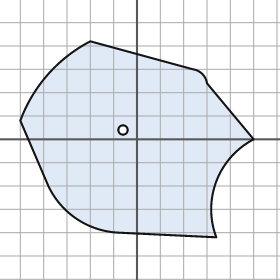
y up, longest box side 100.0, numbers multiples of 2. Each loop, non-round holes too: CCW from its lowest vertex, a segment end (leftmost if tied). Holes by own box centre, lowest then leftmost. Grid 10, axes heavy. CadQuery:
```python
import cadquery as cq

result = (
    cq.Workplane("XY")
    .moveTo(34.0, -42.0)
    .threePointArc((34.0, -18.0), (50.0, 0.0))
    .lineTo(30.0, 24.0)
    .threePointArc((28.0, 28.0), (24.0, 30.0))
    .lineTo(-20.0, 42.0)
    .threePointArc((-38.0, 28.0), (-50.0, 8.0))
    .lineTo(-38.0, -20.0)
    .threePointArc((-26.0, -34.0), (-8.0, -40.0))
    .close()
    .moveTo(-6.0, 4.0)
    .circle(2.0)
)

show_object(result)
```